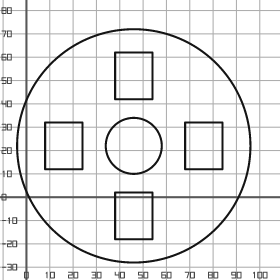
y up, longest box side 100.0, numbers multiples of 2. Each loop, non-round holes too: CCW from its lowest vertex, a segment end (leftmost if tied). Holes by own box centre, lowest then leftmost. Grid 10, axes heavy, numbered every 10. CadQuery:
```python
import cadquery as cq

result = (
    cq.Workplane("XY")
    .moveTo(46.0, 22.0)
    .circle(50.0)
    .moveTo(38.0, -18.0)
    .lineTo(54.0, -18.0)
    .lineTo(54.0, 2.0)
    .lineTo(38.0, 2.0)
    .close()
    .moveTo(8.0, 12.0)
    .lineTo(24.0, 12.0)
    .lineTo(24.0, 32.0)
    .lineTo(8.0, 32.0)
    .close()
    .moveTo(46.0, 22.0)
    .circle(12.0)
    .moveTo(68.0, 12.0)
    .lineTo(84.0, 12.0)
    .lineTo(84.0, 32.0)
    .lineTo(68.0, 32.0)
    .close()
    .moveTo(38.0, 42.0)
    .lineTo(54.0, 42.0)
    .lineTo(54.0, 62.0)
    .lineTo(38.0, 62.0)
    .close()
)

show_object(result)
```